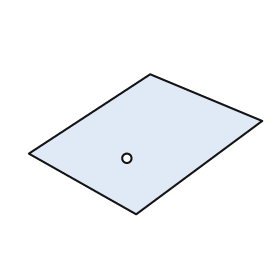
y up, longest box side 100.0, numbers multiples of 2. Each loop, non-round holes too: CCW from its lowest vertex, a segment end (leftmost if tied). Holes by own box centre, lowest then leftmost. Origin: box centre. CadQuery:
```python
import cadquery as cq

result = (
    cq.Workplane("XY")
    .moveTo(-4.0, -30.0)
    .lineTo(50.0, 10.0)
    .lineTo(2.0, 30.0)
    .lineTo(-50.0, -4.0)
    .close()
    .moveTo(-8.0, -6.0)
    .circle(2.0)
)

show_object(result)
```